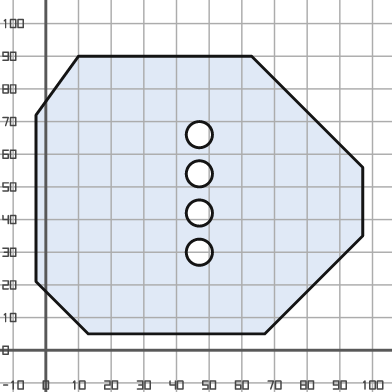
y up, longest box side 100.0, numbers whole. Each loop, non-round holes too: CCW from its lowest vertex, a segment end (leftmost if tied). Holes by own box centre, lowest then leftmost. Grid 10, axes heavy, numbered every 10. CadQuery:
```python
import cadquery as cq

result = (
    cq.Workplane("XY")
    .moveTo(13.0, 5.0)
    .lineTo(67.0, 5.0)
    .lineTo(97.0, 35.0)
    .lineTo(97.0, 56.0)
    .lineTo(63.0, 90.0)
    .lineTo(10.0, 90.0)
    .lineTo(-3.0, 72.0)
    .lineTo(-3.0, 21.0)
    .close()
    .moveTo(47.0, 30.0)
    .circle(4.0)
    .moveTo(47.0, 42.0)
    .circle(4.0)
    .moveTo(47.0, 54.0)
    .circle(4.0)
    .moveTo(47.0, 66.0)
    .circle(4.0)
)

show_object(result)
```